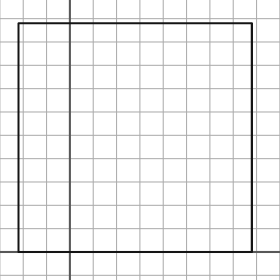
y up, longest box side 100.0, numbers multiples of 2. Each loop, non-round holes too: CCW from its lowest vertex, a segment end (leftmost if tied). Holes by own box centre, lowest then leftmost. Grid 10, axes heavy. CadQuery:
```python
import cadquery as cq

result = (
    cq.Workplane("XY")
    .moveTo(-22.0, 0.0)
    .lineTo(78.0, 0.0)
    .lineTo(78.0, 98.0)
    .lineTo(-22.0, 98.0)
    .close()
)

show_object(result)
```